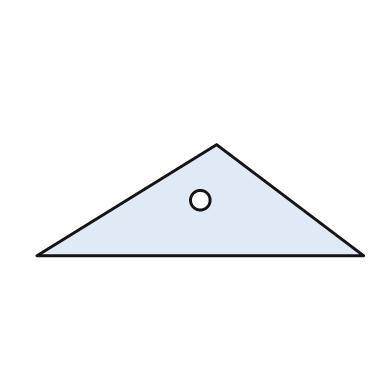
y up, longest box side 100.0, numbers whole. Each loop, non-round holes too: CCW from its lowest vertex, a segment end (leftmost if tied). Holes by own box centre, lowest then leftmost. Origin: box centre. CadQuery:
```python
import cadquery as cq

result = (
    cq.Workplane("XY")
    .moveTo(-50.0, -17.0)
    .lineTo(50.0, -17.0)
    .lineTo(5.0, 17.0)
    .close()
    .moveTo(0.0, 0.0)
    .circle(3.0)
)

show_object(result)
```